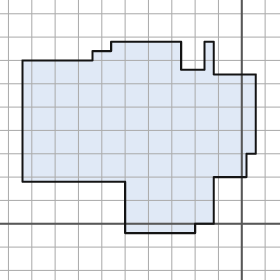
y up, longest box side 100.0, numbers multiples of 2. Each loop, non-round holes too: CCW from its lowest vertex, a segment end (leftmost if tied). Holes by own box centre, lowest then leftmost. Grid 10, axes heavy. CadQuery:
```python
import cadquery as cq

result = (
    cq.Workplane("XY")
    .moveTo(-50.0, -4.0)
    .lineTo(-20.0, -4.0)
    .lineTo(-20.0, 0.0)
    .lineTo(-12.0, 0.0)
    .lineTo(-12.0, 20.0)
    .lineTo(2.0, 20.0)
    .lineTo(2.0, 30.0)
    .lineTo(6.0, 30.0)
    .lineTo(6.0, 64.0)
    .lineTo(-12.0, 64.0)
    .lineTo(-12.0, 78.0)
    .lineTo(-16.0, 78.0)
    .lineTo(-16.0, 66.0)
    .lineTo(-26.0, 66.0)
    .lineTo(-26.0, 78.0)
    .lineTo(-56.0, 78.0)
    .lineTo(-56.0, 74.0)
    .lineTo(-64.0, 74.0)
    .lineTo(-64.0, 70.0)
    .lineTo(-94.0, 70.0)
    .lineTo(-94.0, 18.0)
    .lineTo(-50.0, 18.0)
    .close()
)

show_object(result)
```